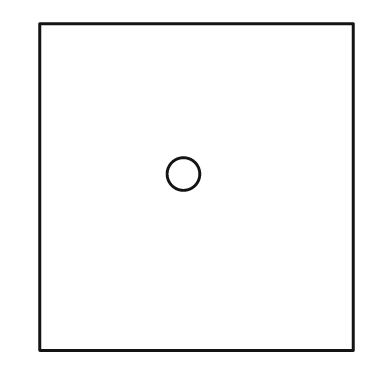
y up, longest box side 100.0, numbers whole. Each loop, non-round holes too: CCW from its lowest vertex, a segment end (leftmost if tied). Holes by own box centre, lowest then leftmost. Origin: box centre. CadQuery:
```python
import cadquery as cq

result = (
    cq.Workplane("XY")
    .moveTo(-48.0, -50.0)
    .lineTo(48.0, -50.0)
    .lineTo(48.0, 50.0)
    .lineTo(-48.0, 50.0)
    .close()
    .moveTo(-4.0, 4.0)
    .circle(5.0)
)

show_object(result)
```